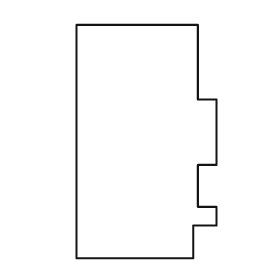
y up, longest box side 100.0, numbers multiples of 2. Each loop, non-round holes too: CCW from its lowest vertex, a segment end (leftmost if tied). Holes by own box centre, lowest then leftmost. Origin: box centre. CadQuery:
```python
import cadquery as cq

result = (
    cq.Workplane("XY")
    .moveTo(-30.0, -50.0)
    .lineTo(20.0, -50.0)
    .lineTo(20.0, -36.0)
    .lineTo(30.0, -36.0)
    .lineTo(30.0, -28.0)
    .lineTo(22.0, -28.0)
    .lineTo(22.0, -10.0)
    .lineTo(30.0, -10.0)
    .lineTo(30.0, 18.0)
    .lineTo(22.0, 18.0)
    .lineTo(22.0, 50.0)
    .lineTo(-30.0, 50.0)
    .close()
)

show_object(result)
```